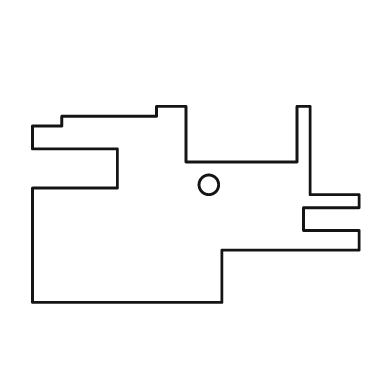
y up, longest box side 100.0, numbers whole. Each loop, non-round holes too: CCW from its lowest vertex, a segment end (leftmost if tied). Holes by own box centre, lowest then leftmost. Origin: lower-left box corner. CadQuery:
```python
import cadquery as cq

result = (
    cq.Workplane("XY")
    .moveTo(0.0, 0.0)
    .lineTo(58.0, 0.0)
    .lineTo(58.0, 16.0)
    .lineTo(100.0, 16.0)
    .lineTo(100.0, 22.0)
    .lineTo(83.0, 22.0)
    .lineTo(83.0, 29.0)
    .lineTo(100.0, 29.0)
    .lineTo(100.0, 33.0)
    .lineTo(85.0, 33.0)
    .lineTo(85.0, 60.0)
    .lineTo(81.0, 60.0)
    .lineTo(81.0, 43.0)
    .lineTo(47.0, 43.0)
    .lineTo(47.0, 60.0)
    .lineTo(38.0, 60.0)
    .lineTo(38.0, 57.0)
    .lineTo(9.0, 57.0)
    .lineTo(9.0, 54.0)
    .lineTo(0.0, 54.0)
    .lineTo(0.0, 47.0)
    .lineTo(26.0, 47.0)
    .lineTo(26.0, 35.0)
    .lineTo(0.0, 35.0)
    .close()
    .moveTo(54.0, 36.0)
    .circle(3.0)
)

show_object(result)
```